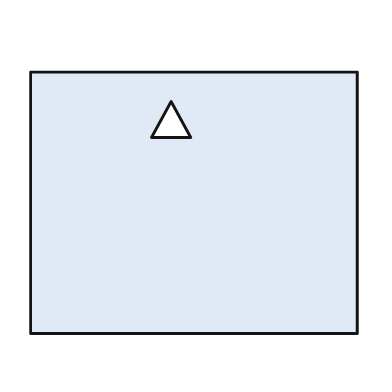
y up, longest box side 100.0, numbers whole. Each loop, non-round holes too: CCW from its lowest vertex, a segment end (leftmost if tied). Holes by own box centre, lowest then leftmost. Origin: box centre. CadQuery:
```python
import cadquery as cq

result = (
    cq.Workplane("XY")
    .moveTo(-50.0, -40.0)
    .lineTo(50.0, -40.0)
    .lineTo(50.0, 40.0)
    .lineTo(-50.0, 40.0)
    .close()
    .moveTo(-13.0, 20.0)
    .lineTo(-1.0, 20.0)
    .lineTo(-7.0, 31.0)
    .close()
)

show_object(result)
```